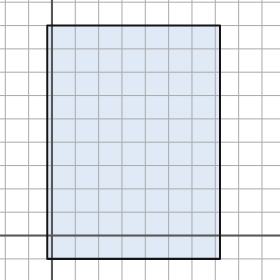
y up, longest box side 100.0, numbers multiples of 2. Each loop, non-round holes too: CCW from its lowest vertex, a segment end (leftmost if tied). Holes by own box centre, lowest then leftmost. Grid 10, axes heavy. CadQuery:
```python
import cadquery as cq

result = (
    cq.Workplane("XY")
    .moveTo(-2.0, -10.0)
    .lineTo(72.0, -10.0)
    .lineTo(72.0, 90.0)
    .lineTo(-2.0, 90.0)
    .close()
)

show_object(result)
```